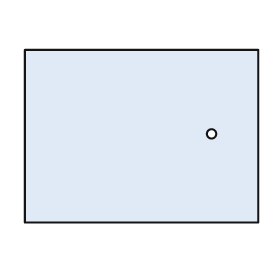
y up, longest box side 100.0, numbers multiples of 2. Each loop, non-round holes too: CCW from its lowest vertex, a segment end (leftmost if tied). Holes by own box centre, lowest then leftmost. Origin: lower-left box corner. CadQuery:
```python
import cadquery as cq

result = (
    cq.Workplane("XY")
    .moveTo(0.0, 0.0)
    .lineTo(100.0, 0.0)
    .lineTo(100.0, 74.0)
    .lineTo(0.0, 74.0)
    .close()
    .moveTo(80.0, 38.0)
    .circle(2.0)
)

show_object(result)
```